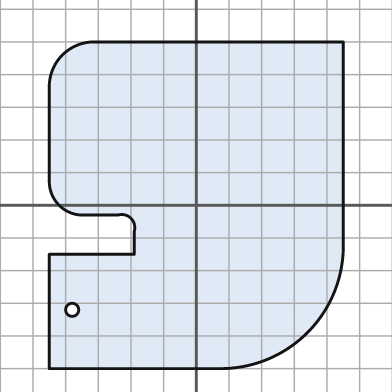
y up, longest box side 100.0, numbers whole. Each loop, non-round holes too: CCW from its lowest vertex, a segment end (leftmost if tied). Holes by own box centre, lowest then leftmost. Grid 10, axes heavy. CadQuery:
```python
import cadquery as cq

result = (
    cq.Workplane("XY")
    .moveTo(-45.0, -50.0)
    .lineTo(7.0, -50.0)
    .threePointArc((34.0, -39.0), (45.0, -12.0))
    .lineTo(45.0, 50.0)
    .lineTo(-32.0, 50.0)
    .threePointArc((-41.0, 46.0), (-45.0, 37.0))
    .lineTo(-45.0, 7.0)
    .threePointArc((-42.0, 0.0), (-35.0, -3.0))
    .lineTo(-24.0, -3.0)
    .threePointArc((-20.0, -4.0), (-19.0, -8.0))
    .lineTo(-19.0, -15.0)
    .lineTo(-45.0, -15.0)
    .close()
    .moveTo(-38.0, -32.0)
    .circle(2.0)
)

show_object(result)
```